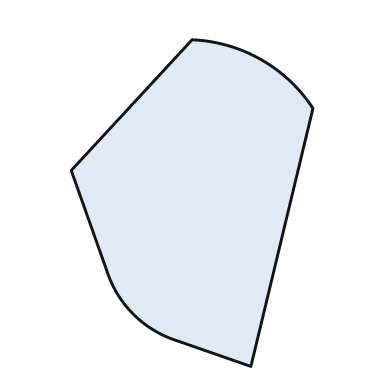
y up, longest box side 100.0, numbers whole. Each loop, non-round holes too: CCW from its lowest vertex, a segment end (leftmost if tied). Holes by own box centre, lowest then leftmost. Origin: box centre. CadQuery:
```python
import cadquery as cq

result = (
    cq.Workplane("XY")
    .moveTo(18.0, -50.0)
    .lineTo(37.0, 29.0)
    .threePointArc((21.0, 44.0), (0.0, 50.0))
    .lineTo(-37.0, 10.0)
    .lineTo(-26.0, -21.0)
    .threePointArc((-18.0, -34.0), (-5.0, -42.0))
    .close()
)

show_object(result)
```